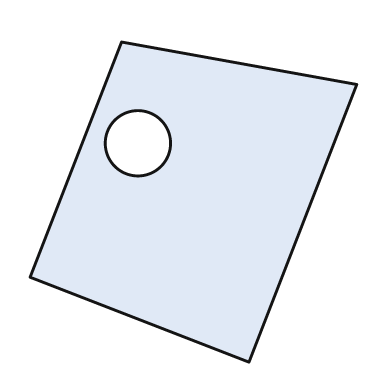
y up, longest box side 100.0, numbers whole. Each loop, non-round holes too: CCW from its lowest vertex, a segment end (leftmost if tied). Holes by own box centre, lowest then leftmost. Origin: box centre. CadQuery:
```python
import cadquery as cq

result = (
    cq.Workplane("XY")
    .moveTo(17.0, -49.0)
    .lineTo(50.0, 36.0)
    .lineTo(-22.0, 49.0)
    .lineTo(-50.0, -23.0)
    .close()
    .moveTo(-17.0, 18.0)
    .circle(10.0)
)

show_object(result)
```